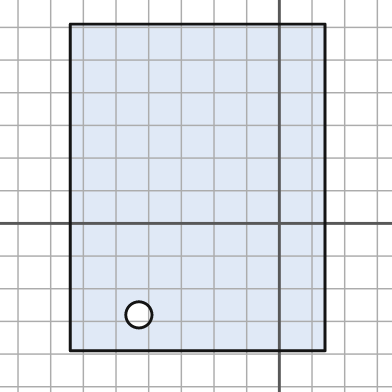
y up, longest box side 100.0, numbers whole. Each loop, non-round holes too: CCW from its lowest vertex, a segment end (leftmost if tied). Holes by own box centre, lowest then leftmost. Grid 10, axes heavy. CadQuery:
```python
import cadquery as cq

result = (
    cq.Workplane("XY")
    .moveTo(-64.0, -39.0)
    .lineTo(14.0, -39.0)
    .lineTo(14.0, 61.0)
    .lineTo(-64.0, 61.0)
    .close()
    .moveTo(-43.0, -28.0)
    .circle(4.0)
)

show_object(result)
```